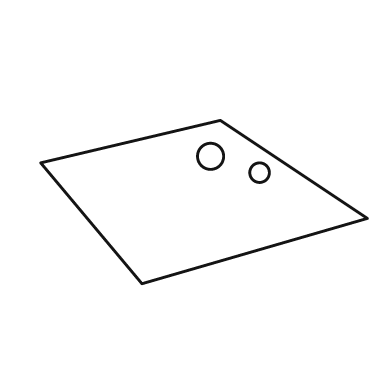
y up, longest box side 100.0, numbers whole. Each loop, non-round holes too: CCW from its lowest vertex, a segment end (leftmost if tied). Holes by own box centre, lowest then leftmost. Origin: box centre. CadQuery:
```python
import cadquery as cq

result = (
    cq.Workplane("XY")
    .moveTo(-19.0, -25.0)
    .lineTo(50.0, -5.0)
    .lineTo(5.0, 25.0)
    .lineTo(-50.0, 12.0)
    .close()
    .moveTo(17.0, 9.0)
    .circle(3.0)
    .moveTo(2.0, 14.0)
    .circle(4.0)
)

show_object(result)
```